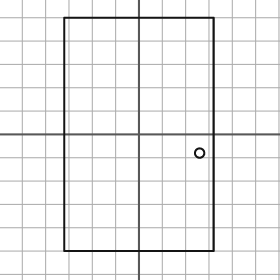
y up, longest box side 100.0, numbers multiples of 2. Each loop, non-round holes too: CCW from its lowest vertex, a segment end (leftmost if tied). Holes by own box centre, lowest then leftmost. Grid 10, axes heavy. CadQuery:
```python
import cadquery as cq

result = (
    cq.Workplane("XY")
    .moveTo(-32.0, -50.0)
    .lineTo(32.0, -50.0)
    .lineTo(32.0, 50.0)
    .lineTo(-32.0, 50.0)
    .close()
    .moveTo(26.0, -8.0)
    .circle(2.0)
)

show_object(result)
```